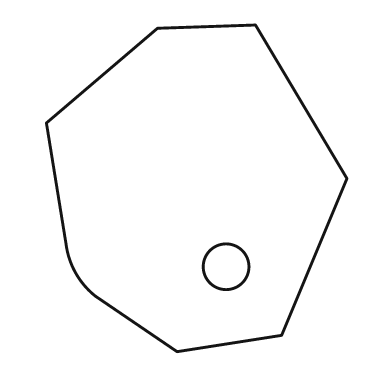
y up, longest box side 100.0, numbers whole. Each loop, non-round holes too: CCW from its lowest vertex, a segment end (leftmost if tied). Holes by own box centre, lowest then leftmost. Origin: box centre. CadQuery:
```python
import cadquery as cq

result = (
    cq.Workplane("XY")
    .moveTo(-6.0, -50.0)
    .lineTo(26.0, -45.0)
    .lineTo(46.0, 3.0)
    .lineTo(18.0, 50.0)
    .lineTo(-12.0, 49.0)
    .lineTo(-46.0, 20.0)
    .lineTo(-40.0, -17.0)
    .threePointArc((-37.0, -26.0), (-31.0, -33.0))
    .close()
    .moveTo(9.0, -24.0)
    .circle(7.0)
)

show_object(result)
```